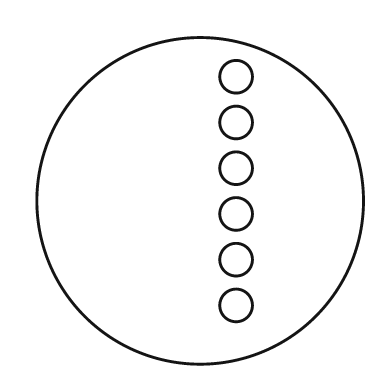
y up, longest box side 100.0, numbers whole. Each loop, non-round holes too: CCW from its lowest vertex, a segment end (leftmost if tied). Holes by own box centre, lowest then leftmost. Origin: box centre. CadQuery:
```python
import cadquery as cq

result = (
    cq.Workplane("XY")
    .moveTo(0.0, 0.0)
    .circle(50.0)
    .moveTo(11.0, -32.0)
    .circle(5.0)
    .moveTo(11.0, -18.0)
    .circle(5.0)
    .moveTo(11.0, -4.0)
    .circle(5.0)
    .moveTo(11.0, 10.0)
    .circle(5.0)
    .moveTo(11.0, 24.0)
    .circle(5.0)
    .moveTo(11.0, 38.0)
    .circle(5.0)
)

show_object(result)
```